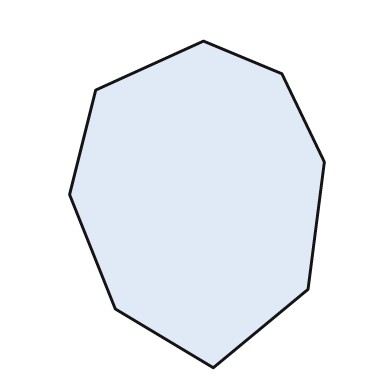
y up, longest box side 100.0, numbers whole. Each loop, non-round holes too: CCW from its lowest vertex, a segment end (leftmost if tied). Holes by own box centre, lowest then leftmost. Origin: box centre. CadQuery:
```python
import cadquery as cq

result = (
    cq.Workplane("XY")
    .moveTo(5.0, -50.0)
    .lineTo(34.0, -26.0)
    .lineTo(39.0, 13.0)
    .lineTo(26.0, 40.0)
    .lineTo(2.0, 50.0)
    .lineTo(-31.0, 35.0)
    .lineTo(-39.0, 3.0)
    .lineTo(-25.0, -32.0)
    .close()
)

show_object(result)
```